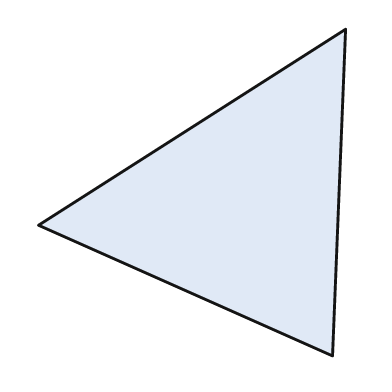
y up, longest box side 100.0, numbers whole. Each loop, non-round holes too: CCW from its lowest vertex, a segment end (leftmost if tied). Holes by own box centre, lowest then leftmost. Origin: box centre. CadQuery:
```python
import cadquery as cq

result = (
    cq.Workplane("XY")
    .moveTo(43.0, -50.0)
    .lineTo(47.0, 50.0)
    .lineTo(-47.0, -10.0)
    .close()
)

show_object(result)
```